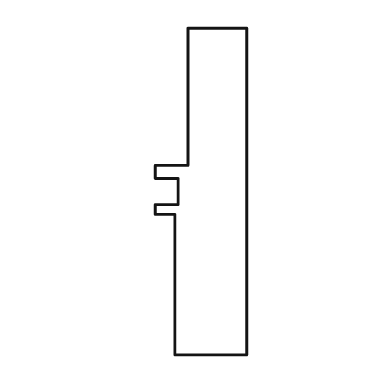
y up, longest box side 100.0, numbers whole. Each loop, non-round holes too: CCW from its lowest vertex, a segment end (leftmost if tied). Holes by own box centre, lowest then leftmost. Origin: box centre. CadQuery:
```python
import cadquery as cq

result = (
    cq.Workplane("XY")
    .moveTo(-8.0, -50.0)
    .lineTo(14.0, -50.0)
    .lineTo(14.0, 50.0)
    .lineTo(-4.0, 50.0)
    .lineTo(-4.0, 8.0)
    .lineTo(-14.0, 8.0)
    .lineTo(-14.0, 4.0)
    .lineTo(-7.0, 4.0)
    .lineTo(-7.0, -4.0)
    .lineTo(-14.0, -4.0)
    .lineTo(-14.0, -7.0)
    .lineTo(-8.0, -7.0)
    .close()
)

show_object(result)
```